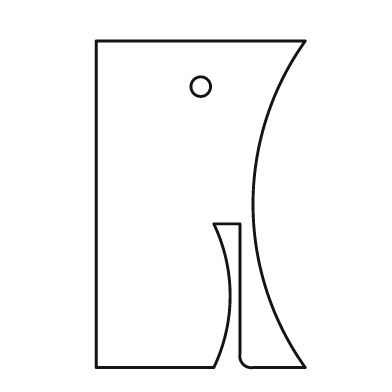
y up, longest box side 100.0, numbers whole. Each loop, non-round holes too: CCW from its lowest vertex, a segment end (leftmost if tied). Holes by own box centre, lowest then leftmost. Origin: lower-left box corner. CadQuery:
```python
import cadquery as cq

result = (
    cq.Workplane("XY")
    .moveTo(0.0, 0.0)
    .lineTo(36.0, 0.0)
    .threePointArc((41.0, 22.0), (36.0, 44.0))
    .lineTo(44.0, 44.0)
    .lineTo(44.0, 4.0)
    .threePointArc((45.0, 1.0), (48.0, 0.0))
    .lineTo(64.0, 0.0)
    .threePointArc((48.0, 50.0), (64.0, 100.0))
    .lineTo(0.0, 100.0)
    .close()
    .moveTo(32.0, 86.0)
    .circle(3.0)
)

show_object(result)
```